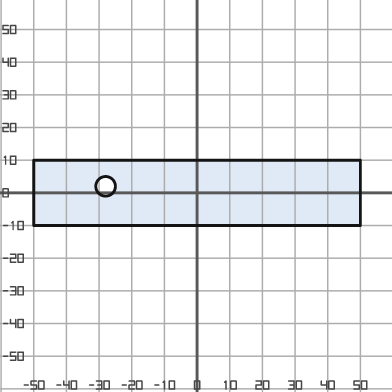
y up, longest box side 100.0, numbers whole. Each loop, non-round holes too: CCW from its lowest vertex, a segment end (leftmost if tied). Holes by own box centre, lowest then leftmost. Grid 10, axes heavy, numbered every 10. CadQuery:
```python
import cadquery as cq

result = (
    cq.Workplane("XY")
    .moveTo(-50.0, -10.0)
    .lineTo(50.0, -10.0)
    .lineTo(50.0, 10.0)
    .lineTo(-50.0, 10.0)
    .close()
    .moveTo(-28.0, 2.0)
    .circle(3.0)
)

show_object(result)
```